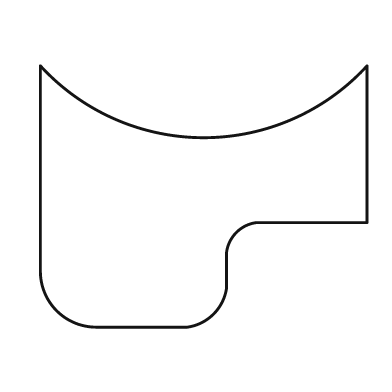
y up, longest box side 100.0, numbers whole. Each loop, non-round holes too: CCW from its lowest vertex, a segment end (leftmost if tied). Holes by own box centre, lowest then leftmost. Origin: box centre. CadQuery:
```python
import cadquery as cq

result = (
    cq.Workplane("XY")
    .moveTo(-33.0, -40.0)
    .lineTo(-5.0, -40.0)
    .threePointArc((3.0, -36.0), (7.0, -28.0))
    .lineTo(7.0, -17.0)
    .threePointArc((10.0, -11.0), (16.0, -8.0))
    .lineTo(50.0, -8.0)
    .lineTo(50.0, 40.0)
    .threePointArc((0.0, 18.0), (-50.0, 40.0))
    .lineTo(-50.0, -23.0)
    .threePointArc((-45.0, -35.0), (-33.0, -40.0))
    .close()
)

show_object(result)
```